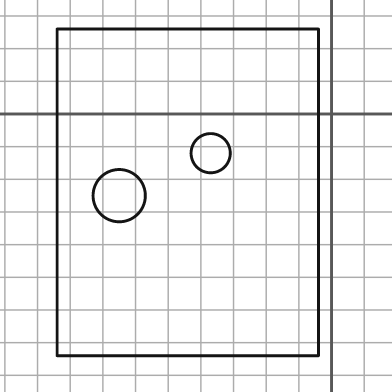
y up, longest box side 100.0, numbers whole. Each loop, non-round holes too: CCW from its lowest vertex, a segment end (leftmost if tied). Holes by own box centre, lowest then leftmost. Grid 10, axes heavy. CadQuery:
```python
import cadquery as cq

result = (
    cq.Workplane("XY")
    .moveTo(-84.0, -74.0)
    .lineTo(-4.0, -74.0)
    .lineTo(-4.0, 26.0)
    .lineTo(-84.0, 26.0)
    .close()
    .moveTo(-65.0, -25.0)
    .circle(8.0)
    .moveTo(-37.0, -12.0)
    .circle(6.0)
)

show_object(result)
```